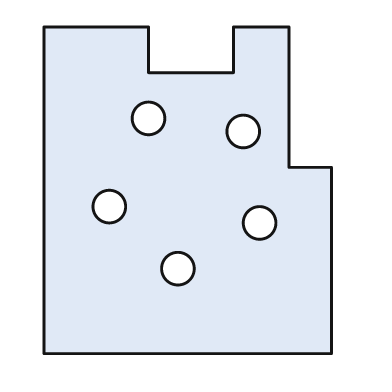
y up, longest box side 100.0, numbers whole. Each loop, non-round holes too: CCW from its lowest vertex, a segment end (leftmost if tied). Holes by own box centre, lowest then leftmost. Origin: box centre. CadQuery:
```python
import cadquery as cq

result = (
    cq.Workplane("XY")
    .moveTo(-44.0, -50.0)
    .lineTo(44.0, -50.0)
    .lineTo(44.0, 7.0)
    .lineTo(31.0, 7.0)
    .lineTo(31.0, 50.0)
    .lineTo(14.0, 50.0)
    .lineTo(14.0, 36.0)
    .lineTo(-12.0, 36.0)
    .lineTo(-12.0, 50.0)
    .lineTo(-44.0, 50.0)
    .close()
    .moveTo(-3.0, -24.0)
    .circle(5.0)
    .moveTo(22.0, -10.0)
    .circle(5.0)
    .moveTo(-24.0, -5.0)
    .circle(5.0)
    .moveTo(17.0, 18.0)
    .circle(5.0)
    .moveTo(-12.0, 22.0)
    .circle(5.0)
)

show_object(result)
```